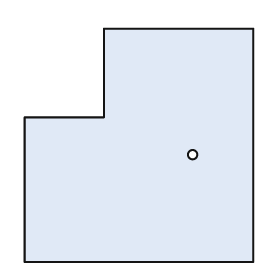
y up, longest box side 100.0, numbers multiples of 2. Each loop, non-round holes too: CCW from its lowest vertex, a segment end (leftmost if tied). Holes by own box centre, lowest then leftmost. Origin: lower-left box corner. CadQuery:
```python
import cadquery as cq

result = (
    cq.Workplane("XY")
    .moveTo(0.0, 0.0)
    .lineTo(98.0, 0.0)
    .lineTo(98.0, 100.0)
    .lineTo(34.0, 100.0)
    .lineTo(34.0, 62.0)
    .lineTo(0.0, 62.0)
    .close()
    .moveTo(72.0, 46.0)
    .circle(2.0)
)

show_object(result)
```